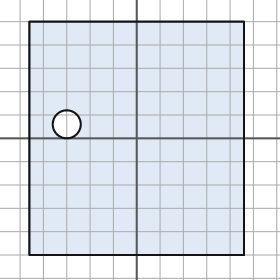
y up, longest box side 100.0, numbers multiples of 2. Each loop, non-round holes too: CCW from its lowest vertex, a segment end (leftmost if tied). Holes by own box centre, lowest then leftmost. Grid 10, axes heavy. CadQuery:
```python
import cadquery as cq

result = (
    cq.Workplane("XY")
    .moveTo(-46.0, -50.0)
    .lineTo(46.0, -50.0)
    .lineTo(46.0, 50.0)
    .lineTo(-46.0, 50.0)
    .close()
    .moveTo(-30.0, 6.0)
    .circle(6.0)
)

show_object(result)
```